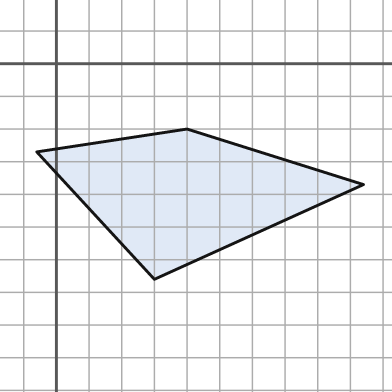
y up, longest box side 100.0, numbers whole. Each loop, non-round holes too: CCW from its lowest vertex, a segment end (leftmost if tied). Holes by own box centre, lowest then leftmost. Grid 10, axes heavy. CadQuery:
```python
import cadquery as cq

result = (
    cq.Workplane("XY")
    .moveTo(30.0, -66.0)
    .lineTo(94.0, -37.0)
    .lineTo(40.0, -20.0)
    .lineTo(-6.0, -27.0)
    .close()
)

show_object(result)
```